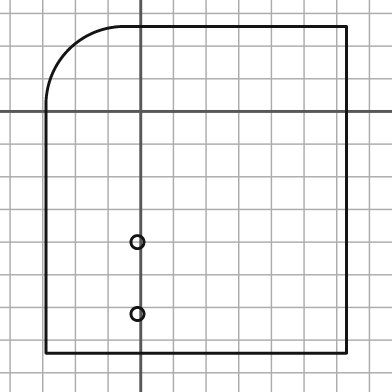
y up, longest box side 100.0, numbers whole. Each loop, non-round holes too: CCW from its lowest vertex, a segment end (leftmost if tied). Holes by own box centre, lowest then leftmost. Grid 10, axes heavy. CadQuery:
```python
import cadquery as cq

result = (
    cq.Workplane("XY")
    .moveTo(-29.0, -74.0)
    .lineTo(63.0, -74.0)
    .lineTo(63.0, 26.0)
    .lineTo(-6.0, 26.0)
    .threePointArc((-22.0, 19.0), (-29.0, 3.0))
    .close()
    .moveTo(-1.0, -62.0)
    .circle(2.0)
    .moveTo(-1.0, -40.0)
    .circle(2.0)
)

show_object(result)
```